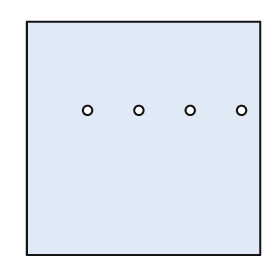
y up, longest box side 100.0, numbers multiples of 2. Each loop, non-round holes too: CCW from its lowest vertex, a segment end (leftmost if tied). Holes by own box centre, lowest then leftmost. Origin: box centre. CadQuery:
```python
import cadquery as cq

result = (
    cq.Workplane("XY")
    .moveTo(-50.0, -50.0)
    .lineTo(50.0, -50.0)
    .lineTo(50.0, 50.0)
    .lineTo(-50.0, 50.0)
    .close()
    .moveTo(-24.0, 12.0)
    .circle(2.0)
    .moveTo(-2.0, 12.0)
    .circle(2.0)
    .moveTo(20.0, 12.0)
    .circle(2.0)
    .moveTo(42.0, 12.0)
    .circle(2.0)
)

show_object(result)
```